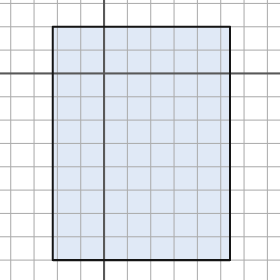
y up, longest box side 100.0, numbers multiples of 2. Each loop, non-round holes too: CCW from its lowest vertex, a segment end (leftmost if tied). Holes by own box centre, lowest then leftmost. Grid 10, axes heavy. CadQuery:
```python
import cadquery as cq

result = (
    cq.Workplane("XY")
    .moveTo(-22.0, -80.0)
    .lineTo(54.0, -80.0)
    .lineTo(54.0, 20.0)
    .lineTo(-22.0, 20.0)
    .close()
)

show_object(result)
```